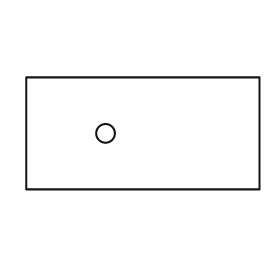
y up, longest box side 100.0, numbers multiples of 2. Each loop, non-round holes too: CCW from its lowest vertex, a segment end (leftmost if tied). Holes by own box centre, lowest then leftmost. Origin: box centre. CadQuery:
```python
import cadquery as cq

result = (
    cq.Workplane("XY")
    .moveTo(-50.0, -24.0)
    .lineTo(50.0, -24.0)
    .lineTo(50.0, 24.0)
    .lineTo(-50.0, 24.0)
    .close()
    .moveTo(-16.0, 0.0)
    .circle(4.0)
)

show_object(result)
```